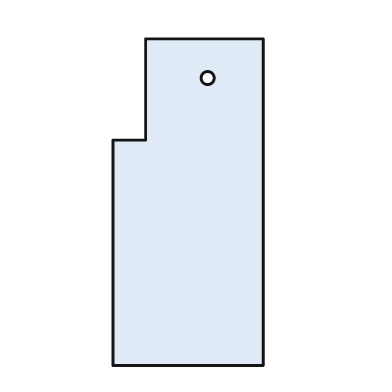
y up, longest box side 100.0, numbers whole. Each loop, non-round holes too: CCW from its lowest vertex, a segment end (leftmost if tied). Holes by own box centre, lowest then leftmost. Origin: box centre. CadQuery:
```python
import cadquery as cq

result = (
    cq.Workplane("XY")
    .moveTo(-23.0, -50.0)
    .lineTo(23.0, -50.0)
    .lineTo(23.0, 50.0)
    .lineTo(-13.0, 50.0)
    .lineTo(-13.0, 19.0)
    .lineTo(-23.0, 19.0)
    .close()
    .moveTo(6.0, 38.0)
    .circle(2.0)
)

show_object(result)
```